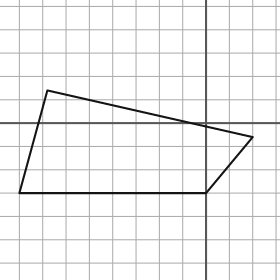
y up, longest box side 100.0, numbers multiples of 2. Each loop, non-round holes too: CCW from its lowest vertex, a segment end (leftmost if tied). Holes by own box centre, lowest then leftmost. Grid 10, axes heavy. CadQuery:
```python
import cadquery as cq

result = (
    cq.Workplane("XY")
    .moveTo(-80.0, -30.0)
    .lineTo(0.0, -30.0)
    .lineTo(20.0, -6.0)
    .lineTo(-68.0, 14.0)
    .close()
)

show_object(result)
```